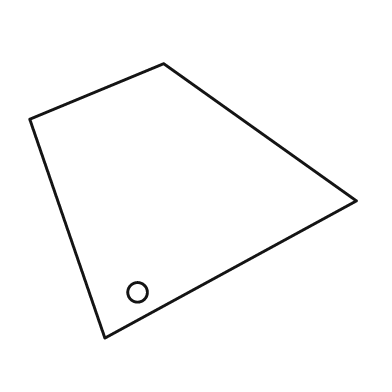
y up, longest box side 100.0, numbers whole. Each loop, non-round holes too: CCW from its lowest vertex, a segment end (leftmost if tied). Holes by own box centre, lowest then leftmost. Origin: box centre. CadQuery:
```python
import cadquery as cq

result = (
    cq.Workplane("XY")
    .moveTo(-27.0, -42.0)
    .lineTo(50.0, 0.0)
    .lineTo(-9.0, 42.0)
    .lineTo(-50.0, 25.0)
    .close()
    .moveTo(-17.0, -28.0)
    .circle(3.0)
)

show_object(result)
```